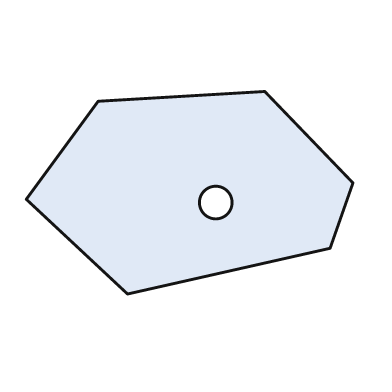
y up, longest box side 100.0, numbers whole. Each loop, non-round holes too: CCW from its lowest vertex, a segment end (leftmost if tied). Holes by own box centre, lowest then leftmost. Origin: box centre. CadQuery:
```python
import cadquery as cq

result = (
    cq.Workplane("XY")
    .moveTo(-19.0, -31.0)
    .lineTo(43.0, -17.0)
    .lineTo(50.0, 3.0)
    .lineTo(23.0, 31.0)
    .lineTo(-28.0, 28.0)
    .lineTo(-50.0, -2.0)
    .close()
    .moveTo(8.0, -3.0)
    .circle(5.0)
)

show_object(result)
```